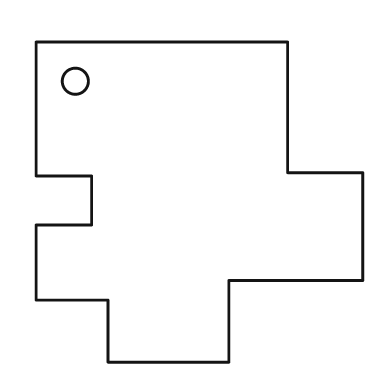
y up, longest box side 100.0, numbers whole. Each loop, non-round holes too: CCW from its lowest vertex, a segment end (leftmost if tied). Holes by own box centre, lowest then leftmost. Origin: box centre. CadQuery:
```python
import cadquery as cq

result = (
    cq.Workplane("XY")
    .moveTo(-28.0, -49.0)
    .lineTo(9.0, -49.0)
    .lineTo(9.0, -24.0)
    .lineTo(50.0, -24.0)
    .lineTo(50.0, 9.0)
    .lineTo(27.0, 9.0)
    .lineTo(27.0, 49.0)
    .lineTo(-50.0, 49.0)
    .lineTo(-50.0, 8.0)
    .lineTo(-33.0, 8.0)
    .lineTo(-33.0, -7.0)
    .lineTo(-50.0, -7.0)
    .lineTo(-50.0, -30.0)
    .lineTo(-28.0, -30.0)
    .close()
    .moveTo(-38.0, 37.0)
    .circle(4.0)
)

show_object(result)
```